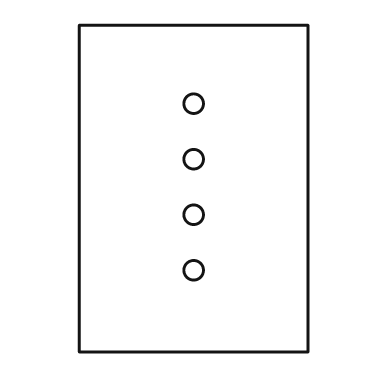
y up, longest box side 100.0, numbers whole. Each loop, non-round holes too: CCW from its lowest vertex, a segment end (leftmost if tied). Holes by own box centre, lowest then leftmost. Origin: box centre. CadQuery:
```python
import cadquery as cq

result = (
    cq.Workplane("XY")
    .moveTo(-35.0, -50.0)
    .lineTo(35.0, -50.0)
    .lineTo(35.0, 50.0)
    .lineTo(-35.0, 50.0)
    .close()
    .moveTo(0.0, -25.0)
    .circle(3.0)
    .moveTo(0.0, -8.0)
    .circle(3.0)
    .moveTo(0.0, 9.0)
    .circle(3.0)
    .moveTo(0.0, 26.0)
    .circle(3.0)
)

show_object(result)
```